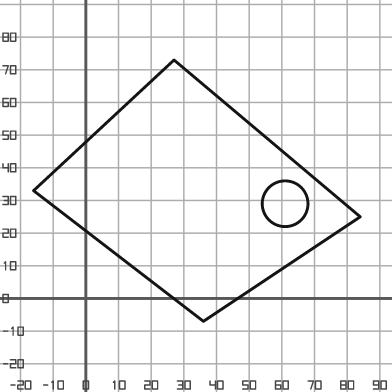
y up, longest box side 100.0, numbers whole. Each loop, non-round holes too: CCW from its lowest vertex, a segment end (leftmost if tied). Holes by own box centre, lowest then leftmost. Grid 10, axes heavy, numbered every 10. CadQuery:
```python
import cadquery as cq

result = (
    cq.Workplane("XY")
    .moveTo(36.0, -7.0)
    .lineTo(84.0, 25.0)
    .lineTo(27.0, 73.0)
    .lineTo(-16.0, 33.0)
    .close()
    .moveTo(61.0, 29.0)
    .circle(7.0)
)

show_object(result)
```